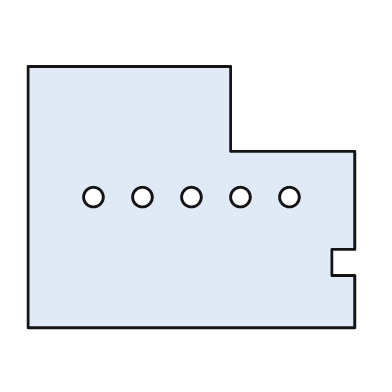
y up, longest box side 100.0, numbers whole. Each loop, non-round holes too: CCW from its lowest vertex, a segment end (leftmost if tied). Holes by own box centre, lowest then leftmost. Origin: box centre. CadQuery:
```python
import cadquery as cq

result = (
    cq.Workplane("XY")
    .moveTo(-50.0, -40.0)
    .lineTo(50.0, -40.0)
    .lineTo(50.0, -24.0)
    .lineTo(43.0, -24.0)
    .lineTo(43.0, -16.0)
    .lineTo(50.0, -16.0)
    .lineTo(50.0, 14.0)
    .lineTo(12.0, 14.0)
    .lineTo(12.0, 40.0)
    .lineTo(-50.0, 40.0)
    .close()
    .moveTo(-30.0, 0.0)
    .circle(3.0)
    .moveTo(-15.0, 0.0)
    .circle(3.0)
    .moveTo(0.0, 0.0)
    .circle(3.0)
    .moveTo(15.0, 0.0)
    .circle(3.0)
    .moveTo(30.0, 0.0)
    .circle(3.0)
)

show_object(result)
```